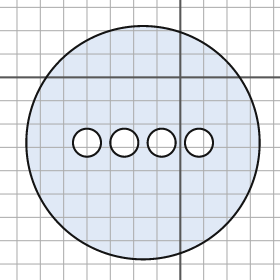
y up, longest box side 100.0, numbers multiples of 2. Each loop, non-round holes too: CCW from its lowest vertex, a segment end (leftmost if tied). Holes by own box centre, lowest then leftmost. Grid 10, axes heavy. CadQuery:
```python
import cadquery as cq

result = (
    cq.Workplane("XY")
    .moveTo(-16.0, -28.0)
    .circle(50.0)
    .moveTo(-40.0, -28.0)
    .circle(6.0)
    .moveTo(-24.0, -28.0)
    .circle(6.0)
    .moveTo(-8.0, -28.0)
    .circle(6.0)
    .moveTo(8.0, -28.0)
    .circle(6.0)
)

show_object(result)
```